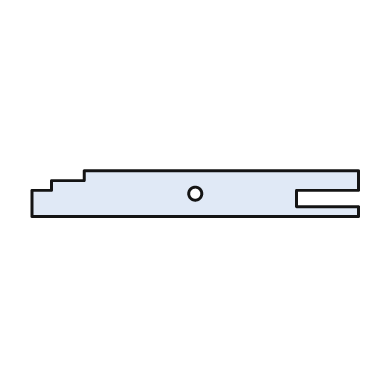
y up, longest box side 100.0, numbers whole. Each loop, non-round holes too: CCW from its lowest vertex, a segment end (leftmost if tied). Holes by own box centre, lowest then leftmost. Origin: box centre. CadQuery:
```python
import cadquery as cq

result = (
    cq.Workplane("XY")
    .moveTo(-50.0, -7.0)
    .lineTo(50.0, -7.0)
    .lineTo(50.0, -4.0)
    .lineTo(31.0, -4.0)
    .lineTo(31.0, 1.0)
    .lineTo(50.0, 1.0)
    .lineTo(50.0, 7.0)
    .lineTo(-34.0, 7.0)
    .lineTo(-34.0, 4.0)
    .lineTo(-44.0, 4.0)
    .lineTo(-44.0, 1.0)
    .lineTo(-50.0, 1.0)
    .close()
    .moveTo(0.0, 0.0)
    .circle(2.0)
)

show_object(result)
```